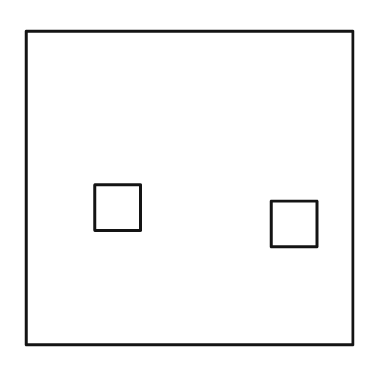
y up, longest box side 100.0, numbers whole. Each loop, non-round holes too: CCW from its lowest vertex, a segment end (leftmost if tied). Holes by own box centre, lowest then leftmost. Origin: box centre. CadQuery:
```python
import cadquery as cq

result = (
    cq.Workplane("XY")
    .moveTo(-50.0, -48.0)
    .lineTo(50.0, -48.0)
    .lineTo(50.0, 48.0)
    .lineTo(-50.0, 48.0)
    .close()
    .moveTo(25.0, -18.0)
    .lineTo(39.0, -18.0)
    .lineTo(39.0, -4.0)
    .lineTo(25.0, -4.0)
    .close()
    .moveTo(-29.0, -13.0)
    .lineTo(-15.0, -13.0)
    .lineTo(-15.0, 1.0)
    .lineTo(-29.0, 1.0)
    .close()
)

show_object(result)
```